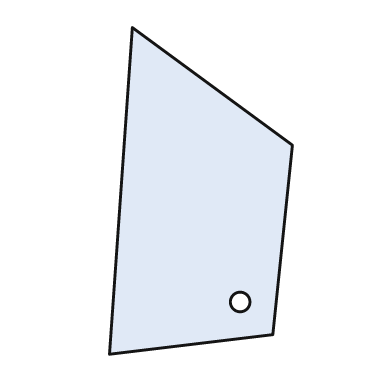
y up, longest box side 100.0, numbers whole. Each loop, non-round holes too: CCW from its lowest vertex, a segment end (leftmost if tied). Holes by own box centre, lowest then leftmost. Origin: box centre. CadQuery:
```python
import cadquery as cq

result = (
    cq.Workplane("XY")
    .moveTo(-28.0, -50.0)
    .lineTo(22.0, -44.0)
    .lineTo(28.0, 14.0)
    .lineTo(-21.0, 50.0)
    .close()
    .moveTo(12.0, -34.0)
    .circle(3.0)
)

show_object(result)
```